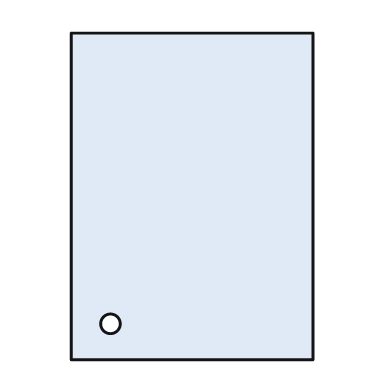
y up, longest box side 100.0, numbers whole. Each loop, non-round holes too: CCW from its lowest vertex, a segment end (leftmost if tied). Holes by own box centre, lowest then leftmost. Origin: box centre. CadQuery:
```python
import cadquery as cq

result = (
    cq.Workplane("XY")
    .moveTo(-37.0, -50.0)
    .lineTo(37.0, -50.0)
    .lineTo(37.0, 50.0)
    .lineTo(-37.0, 50.0)
    .close()
    .moveTo(-25.0, -39.0)
    .circle(3.0)
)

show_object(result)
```